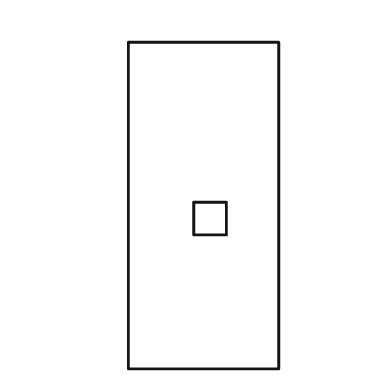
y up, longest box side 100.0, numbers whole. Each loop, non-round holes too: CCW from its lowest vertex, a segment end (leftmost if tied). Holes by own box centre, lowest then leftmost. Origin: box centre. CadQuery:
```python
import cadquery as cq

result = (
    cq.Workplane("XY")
    .moveTo(-23.0, -50.0)
    .lineTo(23.0, -50.0)
    .lineTo(23.0, 50.0)
    .lineTo(-23.0, 50.0)
    .close()
    .moveTo(-3.0, -9.0)
    .lineTo(7.0, -9.0)
    .lineTo(7.0, 1.0)
    .lineTo(-3.0, 1.0)
    .close()
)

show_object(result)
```